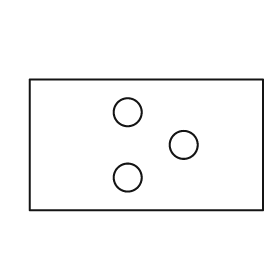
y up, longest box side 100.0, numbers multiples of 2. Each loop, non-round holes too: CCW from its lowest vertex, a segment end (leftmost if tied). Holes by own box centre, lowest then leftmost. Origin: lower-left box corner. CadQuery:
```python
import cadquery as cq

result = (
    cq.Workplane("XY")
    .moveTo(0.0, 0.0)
    .lineTo(100.0, 0.0)
    .lineTo(100.0, 56.0)
    .lineTo(0.0, 56.0)
    .close()
    .moveTo(42.0, 14.0)
    .circle(6.0)
    .moveTo(66.0, 28.0)
    .circle(6.0)
    .moveTo(42.0, 42.0)
    .circle(6.0)
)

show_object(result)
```